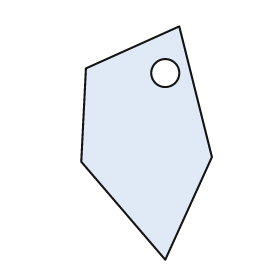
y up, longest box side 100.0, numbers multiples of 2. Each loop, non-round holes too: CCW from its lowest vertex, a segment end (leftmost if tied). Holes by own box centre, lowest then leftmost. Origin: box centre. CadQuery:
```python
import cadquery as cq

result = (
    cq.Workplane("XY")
    .moveTo(8.0, -50.0)
    .lineTo(28.0, -6.0)
    .lineTo(14.0, 50.0)
    .lineTo(-26.0, 32.0)
    .lineTo(-28.0, -8.0)
    .close()
    .moveTo(8.0, 30.0)
    .circle(6.0)
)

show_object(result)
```